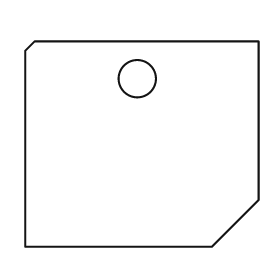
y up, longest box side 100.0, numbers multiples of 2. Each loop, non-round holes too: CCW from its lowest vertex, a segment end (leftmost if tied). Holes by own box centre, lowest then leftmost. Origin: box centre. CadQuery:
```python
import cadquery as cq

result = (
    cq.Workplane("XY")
    .moveTo(-50.0, -44.0)
    .lineTo(30.0, -44.0)
    .lineTo(50.0, -24.0)
    .lineTo(50.0, 44.0)
    .lineTo(-46.0, 44.0)
    .lineTo(-50.0, 40.0)
    .close()
    .moveTo(-2.0, 28.0)
    .circle(8.0)
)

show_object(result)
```